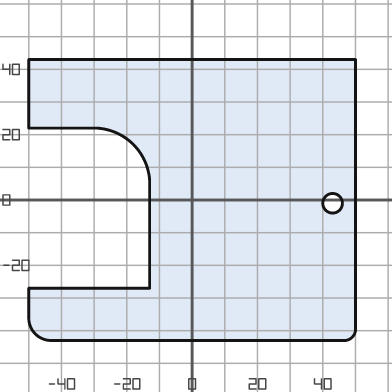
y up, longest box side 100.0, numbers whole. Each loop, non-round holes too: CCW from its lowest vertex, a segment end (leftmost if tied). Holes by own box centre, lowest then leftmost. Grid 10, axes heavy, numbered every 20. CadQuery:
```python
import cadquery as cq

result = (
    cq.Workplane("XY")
    .moveTo(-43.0, -43.0)
    .lineTo(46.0, -43.0)
    .threePointArc((49.0, -42.0), (50.0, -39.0))
    .lineTo(50.0, 43.0)
    .lineTo(-50.0, 43.0)
    .lineTo(-50.0, 22.0)
    .lineTo(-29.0, 22.0)
    .threePointArc((-18.0, 17.0), (-13.0, 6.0))
    .lineTo(-13.0, -27.0)
    .lineTo(-50.0, -27.0)
    .lineTo(-50.0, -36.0)
    .threePointArc((-48.0, -41.0), (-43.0, -43.0))
    .close()
    .moveTo(43.0, -1.0)
    .circle(3.0)
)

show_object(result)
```